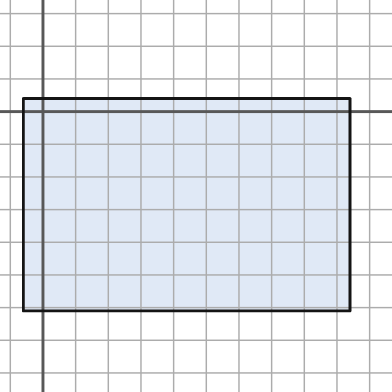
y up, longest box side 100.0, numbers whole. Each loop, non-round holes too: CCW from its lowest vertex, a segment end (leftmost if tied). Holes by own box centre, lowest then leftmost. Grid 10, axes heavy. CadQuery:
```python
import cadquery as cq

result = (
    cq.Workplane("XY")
    .moveTo(-6.0, -61.0)
    .lineTo(94.0, -61.0)
    .lineTo(94.0, 4.0)
    .lineTo(-6.0, 4.0)
    .close()
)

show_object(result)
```